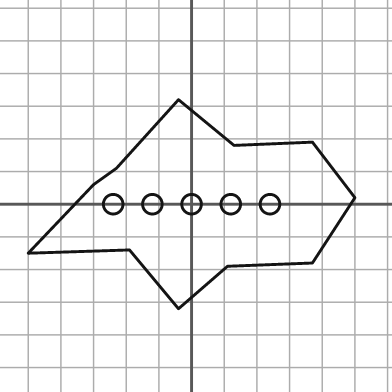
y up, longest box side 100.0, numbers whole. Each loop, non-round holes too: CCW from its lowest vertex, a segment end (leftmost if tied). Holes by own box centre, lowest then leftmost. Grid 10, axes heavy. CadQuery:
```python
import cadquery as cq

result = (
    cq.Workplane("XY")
    .moveTo(-4.0, -32.0)
    .lineTo(11.0, -19.0)
    .lineTo(37.0, -18.0)
    .lineTo(50.0, 2.0)
    .lineTo(37.0, 19.0)
    .lineTo(13.0, 18.0)
    .lineTo(-4.0, 32.0)
    .lineTo(-23.0, 11.0)
    .lineTo(-30.0, 6.0)
    .lineTo(-50.0, -15.0)
    .lineTo(-19.0, -14.0)
    .close()
    .moveTo(-24.0, 0.0)
    .circle(3.0)
    .moveTo(-12.0, 0.0)
    .circle(3.0)
    .moveTo(0.0, 0.0)
    .circle(3.0)
    .moveTo(12.0, 0.0)
    .circle(3.0)
    .moveTo(24.0, 0.0)
    .circle(3.0)
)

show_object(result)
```